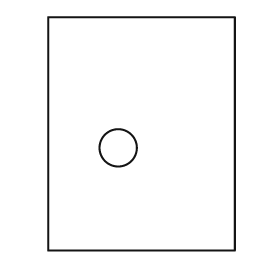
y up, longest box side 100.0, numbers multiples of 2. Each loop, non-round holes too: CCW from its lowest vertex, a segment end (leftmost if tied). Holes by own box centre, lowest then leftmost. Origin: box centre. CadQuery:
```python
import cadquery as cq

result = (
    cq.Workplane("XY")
    .moveTo(-40.0, -50.0)
    .lineTo(40.0, -50.0)
    .lineTo(40.0, 50.0)
    .lineTo(-40.0, 50.0)
    .close()
    .moveTo(-10.0, -6.0)
    .circle(8.0)
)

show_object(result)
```